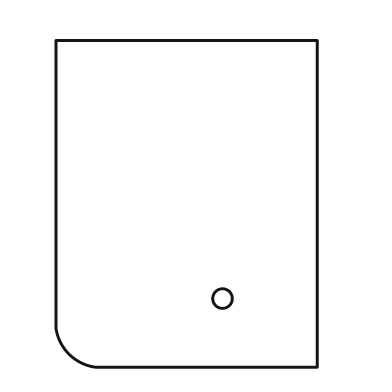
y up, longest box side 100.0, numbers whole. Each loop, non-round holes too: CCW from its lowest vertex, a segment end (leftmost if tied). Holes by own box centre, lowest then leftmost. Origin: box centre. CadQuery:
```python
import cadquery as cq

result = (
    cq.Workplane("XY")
    .moveTo(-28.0, -50.0)
    .lineTo(40.0, -50.0)
    .lineTo(40.0, 50.0)
    .lineTo(-40.0, 50.0)
    .lineTo(-40.0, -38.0)
    .threePointArc((-36.0, -46.0), (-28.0, -50.0))
    .close()
    .moveTo(11.0, -29.0)
    .circle(3.0)
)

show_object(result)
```